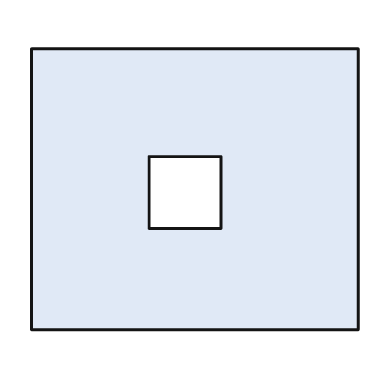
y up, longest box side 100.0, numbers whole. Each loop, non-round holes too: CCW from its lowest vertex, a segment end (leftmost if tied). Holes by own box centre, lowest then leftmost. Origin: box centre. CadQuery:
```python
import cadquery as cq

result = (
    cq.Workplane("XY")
    .moveTo(-50.0, -43.0)
    .lineTo(50.0, -43.0)
    .lineTo(50.0, 43.0)
    .lineTo(-50.0, 43.0)
    .close()
    .moveTo(-14.0, -12.0)
    .lineTo(8.0, -12.0)
    .lineTo(8.0, 10.0)
    .lineTo(-14.0, 10.0)
    .close()
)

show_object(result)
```